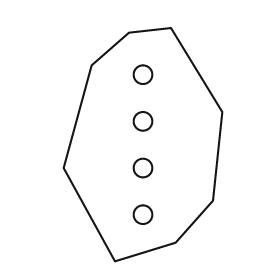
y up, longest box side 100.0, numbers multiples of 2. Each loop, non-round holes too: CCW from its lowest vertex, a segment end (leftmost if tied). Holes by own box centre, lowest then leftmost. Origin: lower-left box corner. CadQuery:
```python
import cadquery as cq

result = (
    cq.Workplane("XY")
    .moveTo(22.0, 0.0)
    .lineTo(48.0, 8.0)
    .lineTo(64.0, 26.0)
    .lineTo(68.0, 64.0)
    .lineTo(46.0, 100.0)
    .lineTo(28.0, 98.0)
    .lineTo(12.0, 84.0)
    .lineTo(0.0, 40.0)
    .close()
    .moveTo(34.0, 20.0)
    .circle(4.0)
    .moveTo(34.0, 40.0)
    .circle(4.0)
    .moveTo(34.0, 60.0)
    .circle(4.0)
    .moveTo(34.0, 80.0)
    .circle(4.0)
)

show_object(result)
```